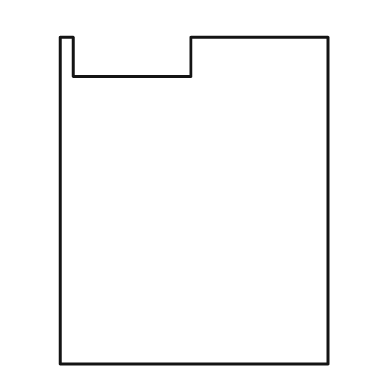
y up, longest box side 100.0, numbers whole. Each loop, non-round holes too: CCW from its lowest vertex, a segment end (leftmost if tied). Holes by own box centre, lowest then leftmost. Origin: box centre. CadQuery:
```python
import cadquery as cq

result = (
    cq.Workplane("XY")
    .moveTo(-41.0, -50.0)
    .lineTo(41.0, -50.0)
    .lineTo(41.0, 50.0)
    .lineTo(-1.0, 50.0)
    .lineTo(-1.0, 38.0)
    .lineTo(-37.0, 38.0)
    .lineTo(-37.0, 50.0)
    .lineTo(-41.0, 50.0)
    .close()
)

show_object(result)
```